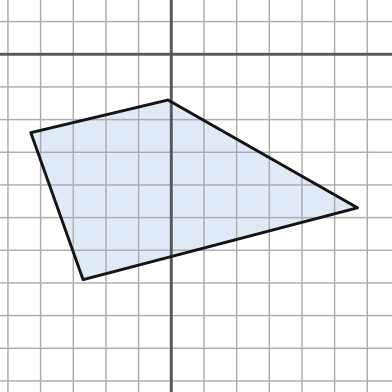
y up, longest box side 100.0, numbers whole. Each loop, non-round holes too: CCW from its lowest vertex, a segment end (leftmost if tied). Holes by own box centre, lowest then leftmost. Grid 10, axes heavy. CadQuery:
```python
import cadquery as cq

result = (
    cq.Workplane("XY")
    .moveTo(-27.0, -69.0)
    .lineTo(57.0, -47.0)
    .lineTo(-1.0, -14.0)
    .lineTo(-43.0, -24.0)
    .close()
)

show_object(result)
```